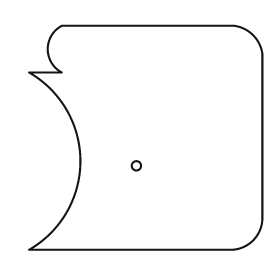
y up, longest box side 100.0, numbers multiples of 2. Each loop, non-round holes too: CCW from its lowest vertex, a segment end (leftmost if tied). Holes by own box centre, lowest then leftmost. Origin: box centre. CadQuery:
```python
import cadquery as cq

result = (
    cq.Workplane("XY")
    .moveTo(-50.0, -48.0)
    .lineTo(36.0, -48.0)
    .threePointArc((46.0, -44.0), (50.0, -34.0))
    .lineTo(50.0, 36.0)
    .threePointArc((46.0, 44.0), (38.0, 48.0))
    .lineTo(-36.0, 48.0)
    .threePointArc((-42.0, 38.0), (-36.0, 28.0))
    .lineTo(-50.0, 28.0)
    .threePointArc((-28.0, -10.0), (-50.0, -48.0))
    .close()
    .moveTo(-4.0, -12.0)
    .circle(2.0)
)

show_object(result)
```